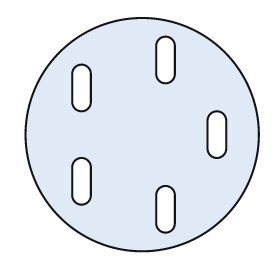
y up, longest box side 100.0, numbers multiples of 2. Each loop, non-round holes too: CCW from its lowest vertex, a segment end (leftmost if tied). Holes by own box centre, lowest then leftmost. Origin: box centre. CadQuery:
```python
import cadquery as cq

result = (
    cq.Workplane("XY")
    .moveTo(0.0, 0.0)
    .circle(50.0)
    .moveTo(6.0, -38.0)
    .threePointArc((10.0, -42.0), (14.0, -38.0))
    .lineTo(14.0, -26.0)
    .threePointArc((10.0, -22.0), (6.0, -26.0))
    .close()
    .moveTo(-30.0, -26.0)
    .threePointArc((-26.0, -30.0), (-22.0, -26.0))
    .lineTo(-22.0, -14.0)
    .threePointArc((-26.0, -10.0), (-30.0, -14.0))
    .close()
    .moveTo(28.0, -6.0)
    .threePointArc((32.0, -10.0), (36.0, -6.0))
    .lineTo(36.0, 6.0)
    .threePointArc((32.0, 10.0), (28.0, 6.0))
    .close()
    .moveTo(-30.0, 14.0)
    .threePointArc((-26.0, 10.0), (-22.0, 14.0))
    .lineTo(-22.0, 26.0)
    .threePointArc((-26.0, 30.0), (-30.0, 26.0))
    .close()
    .moveTo(6.0, 26.0)
    .threePointArc((10.0, 22.0), (14.0, 26.0))
    .lineTo(14.0, 38.0)
    .threePointArc((10.0, 42.0), (6.0, 38.0))
    .close()
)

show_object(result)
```